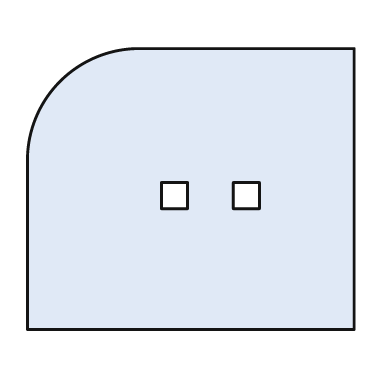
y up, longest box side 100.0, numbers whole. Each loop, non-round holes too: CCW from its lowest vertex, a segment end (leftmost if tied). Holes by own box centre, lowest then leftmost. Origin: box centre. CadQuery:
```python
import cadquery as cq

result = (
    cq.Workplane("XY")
    .moveTo(-50.0, -43.0)
    .lineTo(50.0, -43.0)
    .lineTo(50.0, 43.0)
    .lineTo(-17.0, 43.0)
    .threePointArc((-40.0, 33.0), (-50.0, 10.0))
    .close()
    .moveTo(-9.0, -6.0)
    .lineTo(-1.0, -6.0)
    .lineTo(-1.0, 2.0)
    .lineTo(-9.0, 2.0)
    .close()
    .moveTo(13.0, -6.0)
    .lineTo(21.0, -6.0)
    .lineTo(21.0, 2.0)
    .lineTo(13.0, 2.0)
    .close()
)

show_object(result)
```